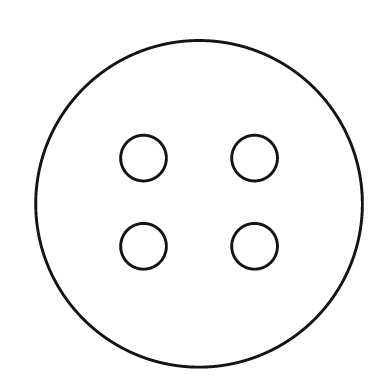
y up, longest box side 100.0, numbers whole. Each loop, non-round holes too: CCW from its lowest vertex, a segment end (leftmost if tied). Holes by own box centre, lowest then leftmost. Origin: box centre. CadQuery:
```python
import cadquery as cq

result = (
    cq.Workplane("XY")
    .moveTo(0.0, 0.0)
    .circle(50.0)
    .moveTo(-17.0, -13.0)
    .circle(7.0)
    .moveTo(17.0, -13.0)
    .circle(7.0)
    .moveTo(-17.0, 14.0)
    .circle(7.0)
    .moveTo(17.0, 14.0)
    .circle(7.0)
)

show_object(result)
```